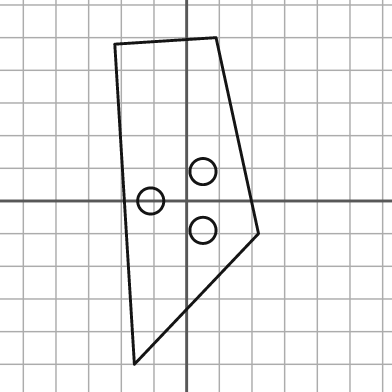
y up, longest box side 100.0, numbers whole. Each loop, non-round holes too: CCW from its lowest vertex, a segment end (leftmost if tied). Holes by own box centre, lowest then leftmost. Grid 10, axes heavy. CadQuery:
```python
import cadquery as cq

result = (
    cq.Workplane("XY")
    .moveTo(-16.0, -50.0)
    .lineTo(22.0, -10.0)
    .lineTo(9.0, 50.0)
    .lineTo(-22.0, 48.0)
    .close()
    .moveTo(5.0, -9.0)
    .circle(4.0)
    .moveTo(-11.0, 0.0)
    .circle(4.0)
    .moveTo(5.0, 9.0)
    .circle(4.0)
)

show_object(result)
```